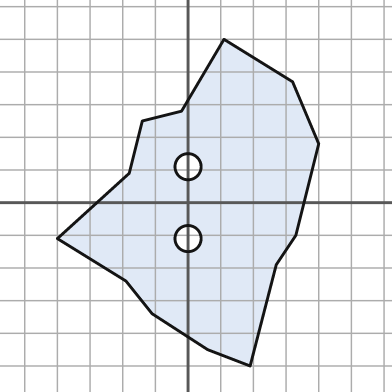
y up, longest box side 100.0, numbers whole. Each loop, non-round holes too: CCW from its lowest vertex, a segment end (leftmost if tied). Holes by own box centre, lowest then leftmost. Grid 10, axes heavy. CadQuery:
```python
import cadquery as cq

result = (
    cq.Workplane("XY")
    .moveTo(19.0, -50.0)
    .lineTo(27.0, -19.0)
    .lineTo(33.0, -10.0)
    .lineTo(40.0, 18.0)
    .lineTo(32.0, 37.0)
    .lineTo(11.0, 50.0)
    .lineTo(-2.0, 28.0)
    .lineTo(-14.0, 25.0)
    .lineTo(-18.0, 9.0)
    .lineTo(-40.0, -11.0)
    .lineTo(-19.0, -24.0)
    .lineTo(-11.0, -34.0)
    .lineTo(6.0, -45.0)
    .close()
    .moveTo(0.0, -11.0)
    .circle(4.0)
    .moveTo(0.0, 11.0)
    .circle(4.0)
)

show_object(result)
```